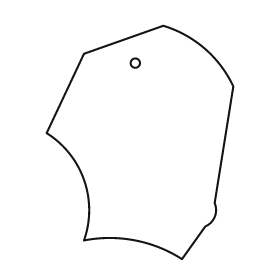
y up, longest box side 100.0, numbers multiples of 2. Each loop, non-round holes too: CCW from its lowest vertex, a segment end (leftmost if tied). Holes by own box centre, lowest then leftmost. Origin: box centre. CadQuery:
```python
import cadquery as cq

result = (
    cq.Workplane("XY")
    .moveTo(18.0, -50.0)
    .lineTo(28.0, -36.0)
    .threePointArc((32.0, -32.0), (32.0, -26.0))
    .lineTo(40.0, 24.0)
    .threePointArc((28.0, 40.0), (10.0, 50.0))
    .lineTo(-24.0, 38.0)
    .lineTo(-40.0, 4.0)
    .threePointArc((-24.0, -16.0), (-24.0, -42.0))
    .threePointArc((-2.0, -42.0), (18.0, -50.0))
    .close()
    .moveTo(-2.0, 34.0)
    .circle(2.0)
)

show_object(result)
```